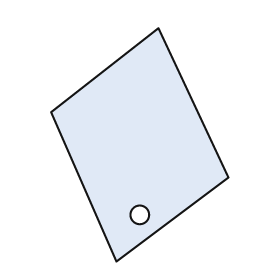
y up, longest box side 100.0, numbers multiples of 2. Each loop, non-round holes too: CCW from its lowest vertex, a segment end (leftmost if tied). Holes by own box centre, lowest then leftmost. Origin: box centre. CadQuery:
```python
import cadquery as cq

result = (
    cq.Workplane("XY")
    .moveTo(-10.0, -50.0)
    .lineTo(38.0, -14.0)
    .lineTo(8.0, 50.0)
    .lineTo(-38.0, 14.0)
    .close()
    .moveTo(0.0, -30.0)
    .circle(4.0)
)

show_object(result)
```